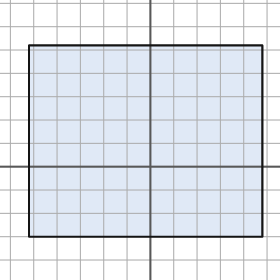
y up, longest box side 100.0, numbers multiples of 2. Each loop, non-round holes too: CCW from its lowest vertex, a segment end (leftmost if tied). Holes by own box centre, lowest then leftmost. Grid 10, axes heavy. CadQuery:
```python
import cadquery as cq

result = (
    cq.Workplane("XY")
    .moveTo(-52.0, -30.0)
    .lineTo(48.0, -30.0)
    .lineTo(48.0, 52.0)
    .lineTo(-52.0, 52.0)
    .close()
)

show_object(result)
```